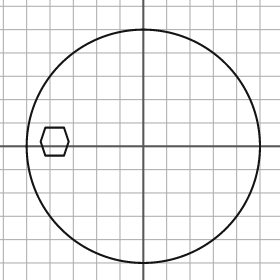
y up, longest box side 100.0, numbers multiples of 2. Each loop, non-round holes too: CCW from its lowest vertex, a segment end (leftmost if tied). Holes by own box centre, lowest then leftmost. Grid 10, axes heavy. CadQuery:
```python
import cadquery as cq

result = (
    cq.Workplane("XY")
    .moveTo(0.0, 0.0)
    .circle(50.0)
    .moveTo(-42.0, -4.0)
    .lineTo(-34.0, -4.0)
    .lineTo(-32.0, 2.0)
    .lineTo(-34.0, 8.0)
    .lineTo(-42.0, 8.0)
    .lineTo(-44.0, 2.0)
    .close()
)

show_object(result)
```